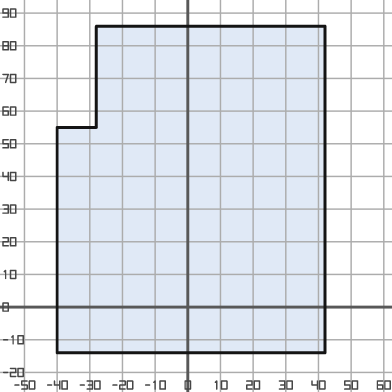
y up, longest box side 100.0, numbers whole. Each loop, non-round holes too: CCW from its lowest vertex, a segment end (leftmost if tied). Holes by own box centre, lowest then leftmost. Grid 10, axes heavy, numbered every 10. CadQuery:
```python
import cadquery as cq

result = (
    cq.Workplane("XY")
    .moveTo(-40.0, -14.0)
    .lineTo(42.0, -14.0)
    .lineTo(42.0, 86.0)
    .lineTo(-28.0, 86.0)
    .lineTo(-28.0, 55.0)
    .lineTo(-40.0, 55.0)
    .close()
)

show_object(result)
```